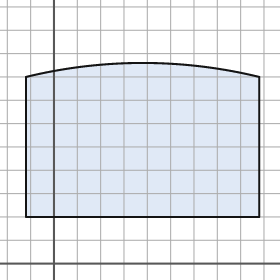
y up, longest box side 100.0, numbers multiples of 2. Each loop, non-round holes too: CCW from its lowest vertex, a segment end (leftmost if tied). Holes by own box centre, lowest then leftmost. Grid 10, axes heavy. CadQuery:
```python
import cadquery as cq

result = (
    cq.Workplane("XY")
    .moveTo(-12.0, 20.0)
    .lineTo(88.0, 20.0)
    .lineTo(88.0, 80.0)
    .threePointArc((38.0, 86.0), (-12.0, 80.0))
    .close()
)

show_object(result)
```